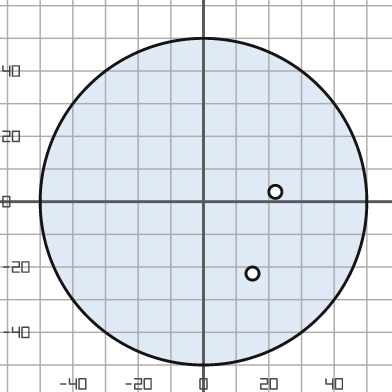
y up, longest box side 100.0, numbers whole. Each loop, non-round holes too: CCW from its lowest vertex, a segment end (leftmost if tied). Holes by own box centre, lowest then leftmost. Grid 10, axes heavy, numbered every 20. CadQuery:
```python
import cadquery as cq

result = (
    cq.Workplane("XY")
    .moveTo(0.0, 0.0)
    .circle(50.0)
    .moveTo(15.0, -22.0)
    .circle(2.0)
    .moveTo(22.0, 3.0)
    .circle(2.0)
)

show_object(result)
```